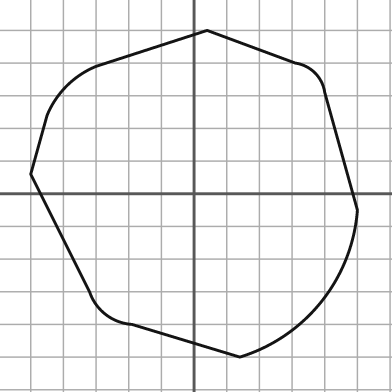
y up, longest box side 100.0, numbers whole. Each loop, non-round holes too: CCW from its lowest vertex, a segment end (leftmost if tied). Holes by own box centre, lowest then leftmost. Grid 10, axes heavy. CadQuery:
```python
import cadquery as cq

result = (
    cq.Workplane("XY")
    .moveTo(14.0, -50.0)
    .threePointArc((39.0, -33.0), (50.0, -5.0))
    .lineTo(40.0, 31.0)
    .threePointArc((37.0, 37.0), (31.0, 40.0))
    .lineTo(4.0, 50.0)
    .lineTo(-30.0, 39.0)
    .threePointArc((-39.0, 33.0), (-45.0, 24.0))
    .lineTo(-50.0, 6.0)
    .lineTo(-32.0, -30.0)
    .threePointArc((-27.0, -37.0), (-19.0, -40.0))
    .close()
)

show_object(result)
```